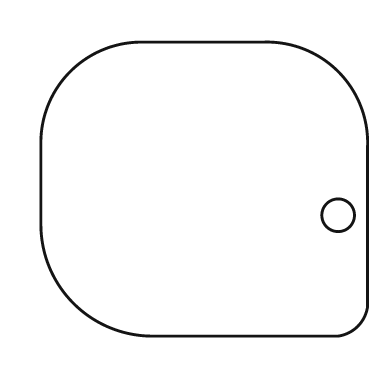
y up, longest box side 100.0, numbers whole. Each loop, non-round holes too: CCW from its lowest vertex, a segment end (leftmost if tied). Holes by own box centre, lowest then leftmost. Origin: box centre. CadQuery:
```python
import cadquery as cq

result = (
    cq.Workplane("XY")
    .moveTo(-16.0, -45.0)
    .lineTo(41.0, -45.0)
    .threePointArc((47.0, -42.0), (50.0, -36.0))
    .lineTo(50.0, 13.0)
    .threePointArc((41.0, 36.0), (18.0, 45.0))
    .lineTo(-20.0, 45.0)
    .threePointArc((-41.0, 36.0), (-50.0, 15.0))
    .lineTo(-50.0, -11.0)
    .threePointArc((-40.0, -35.0), (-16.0, -45.0))
    .close()
    .moveTo(41.0, -8.0)
    .circle(5.0)
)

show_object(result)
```